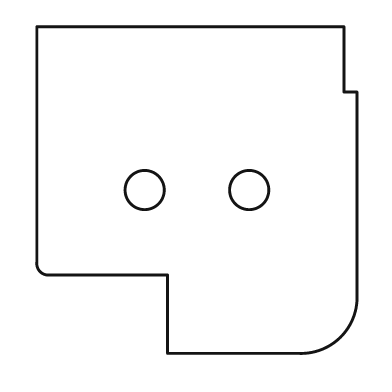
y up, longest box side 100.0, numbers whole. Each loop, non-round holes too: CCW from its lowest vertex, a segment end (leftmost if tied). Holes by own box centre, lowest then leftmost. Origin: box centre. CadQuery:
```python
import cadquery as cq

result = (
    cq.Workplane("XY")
    .moveTo(-9.0, -50.0)
    .lineTo(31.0, -50.0)
    .threePointArc((44.0, -45.0), (49.0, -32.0))
    .lineTo(49.0, 30.0)
    .lineTo(45.0, 30.0)
    .lineTo(45.0, 50.0)
    .lineTo(-49.0, 50.0)
    .lineTo(-49.0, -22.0)
    .threePointArc((-48.0, -25.0), (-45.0, -26.0))
    .lineTo(-9.0, -26.0)
    .close()
    .moveTo(-16.0, 0.0)
    .circle(6.0)
    .moveTo(16.0, 0.0)
    .circle(6.0)
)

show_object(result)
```